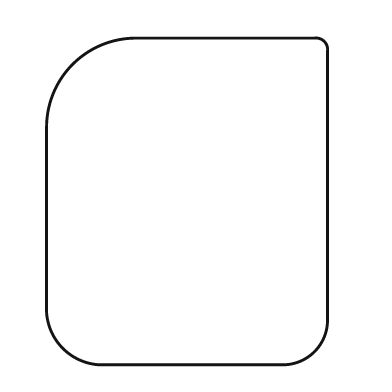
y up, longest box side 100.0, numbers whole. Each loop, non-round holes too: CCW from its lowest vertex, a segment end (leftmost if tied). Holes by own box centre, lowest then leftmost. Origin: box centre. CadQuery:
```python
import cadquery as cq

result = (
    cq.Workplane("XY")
    .moveTo(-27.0, -50.0)
    .lineTo(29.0, -50.0)
    .threePointArc((39.0, -46.0), (43.0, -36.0))
    .lineTo(43.0, 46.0)
    .threePointArc((42.0, 49.0), (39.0, 50.0))
    .lineTo(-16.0, 50.0)
    .threePointArc((-35.0, 42.0), (-43.0, 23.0))
    .lineTo(-43.0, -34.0)
    .threePointArc((-38.0, -45.0), (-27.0, -50.0))
    .close()
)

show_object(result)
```